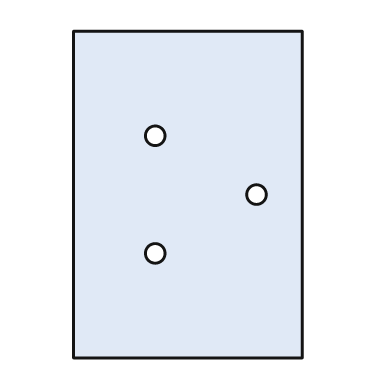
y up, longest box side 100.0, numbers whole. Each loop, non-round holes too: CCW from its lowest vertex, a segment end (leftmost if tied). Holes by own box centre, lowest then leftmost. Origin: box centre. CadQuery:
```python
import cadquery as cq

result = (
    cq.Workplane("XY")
    .moveTo(-35.0, -50.0)
    .lineTo(35.0, -50.0)
    .lineTo(35.0, 50.0)
    .lineTo(-35.0, 50.0)
    .close()
    .moveTo(-10.0, -18.0)
    .circle(3.0)
    .moveTo(21.0, 0.0)
    .circle(3.0)
    .moveTo(-10.0, 18.0)
    .circle(3.0)
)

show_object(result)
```